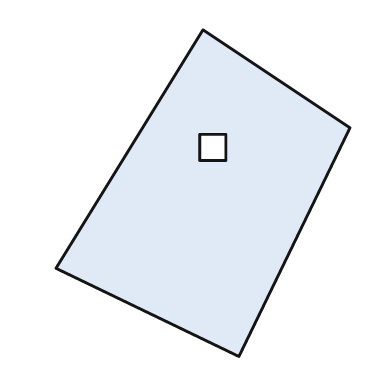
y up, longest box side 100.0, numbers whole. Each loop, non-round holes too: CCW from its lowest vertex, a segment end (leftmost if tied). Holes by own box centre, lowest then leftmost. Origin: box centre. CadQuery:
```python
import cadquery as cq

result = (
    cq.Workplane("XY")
    .moveTo(11.0, -50.0)
    .lineTo(45.0, 20.0)
    .lineTo(0.0, 50.0)
    .lineTo(-45.0, -23.0)
    .close()
    .moveTo(-1.0, 10.0)
    .lineTo(7.0, 10.0)
    .lineTo(7.0, 18.0)
    .lineTo(-1.0, 18.0)
    .close()
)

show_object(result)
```